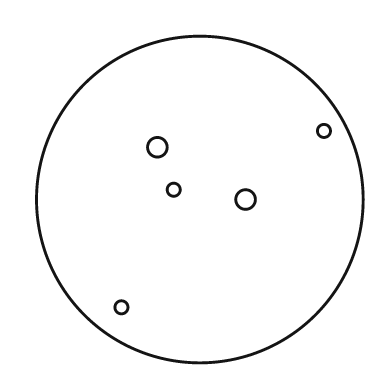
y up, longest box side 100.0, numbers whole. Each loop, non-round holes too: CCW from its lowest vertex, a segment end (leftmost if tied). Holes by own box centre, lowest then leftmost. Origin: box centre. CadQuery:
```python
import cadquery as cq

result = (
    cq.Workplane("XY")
    .moveTo(0.0, 0.0)
    .circle(50.0)
    .moveTo(-24.0, -33.0)
    .circle(2.0)
    .moveTo(14.0, 0.0)
    .circle(3.0)
    .moveTo(-8.0, 3.0)
    .circle(2.0)
    .moveTo(-13.0, 16.0)
    .circle(3.0)
    .moveTo(38.0, 21.0)
    .circle(2.0)
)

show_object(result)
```